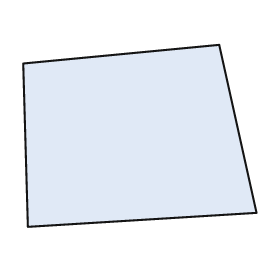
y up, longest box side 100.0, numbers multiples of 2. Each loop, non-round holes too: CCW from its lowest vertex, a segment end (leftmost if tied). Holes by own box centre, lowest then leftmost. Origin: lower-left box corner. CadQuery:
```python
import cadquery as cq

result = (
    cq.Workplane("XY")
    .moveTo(2.0, 0.0)
    .lineTo(100.0, 6.0)
    .lineTo(84.0, 78.0)
    .lineTo(0.0, 70.0)
    .close()
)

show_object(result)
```